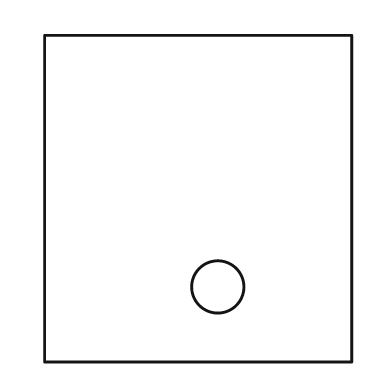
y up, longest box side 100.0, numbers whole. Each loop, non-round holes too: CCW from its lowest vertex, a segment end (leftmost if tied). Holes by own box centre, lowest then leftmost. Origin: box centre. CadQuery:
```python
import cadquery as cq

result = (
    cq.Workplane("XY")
    .moveTo(-47.0, -50.0)
    .lineTo(47.0, -50.0)
    .lineTo(47.0, 50.0)
    .lineTo(-47.0, 50.0)
    .close()
    .moveTo(6.0, -27.0)
    .circle(8.0)
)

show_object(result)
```